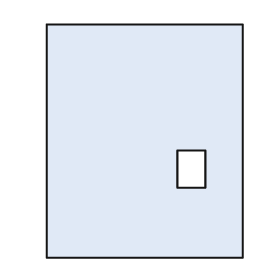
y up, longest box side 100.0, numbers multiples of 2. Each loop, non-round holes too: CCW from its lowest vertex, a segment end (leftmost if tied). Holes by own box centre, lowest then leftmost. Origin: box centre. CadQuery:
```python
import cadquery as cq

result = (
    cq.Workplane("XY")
    .moveTo(-42.0, -50.0)
    .lineTo(42.0, -50.0)
    .lineTo(42.0, 50.0)
    .lineTo(-42.0, 50.0)
    .close()
    .moveTo(14.0, -20.0)
    .lineTo(26.0, -20.0)
    .lineTo(26.0, -4.0)
    .lineTo(14.0, -4.0)
    .close()
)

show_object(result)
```